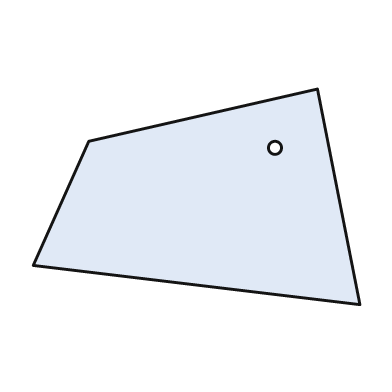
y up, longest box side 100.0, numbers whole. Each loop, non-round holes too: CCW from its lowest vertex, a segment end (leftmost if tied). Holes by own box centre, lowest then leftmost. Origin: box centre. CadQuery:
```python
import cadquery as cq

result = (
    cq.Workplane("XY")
    .moveTo(50.0, -33.0)
    .lineTo(37.0, 33.0)
    .lineTo(-33.0, 17.0)
    .lineTo(-50.0, -21.0)
    .close()
    .moveTo(24.0, 15.0)
    .circle(2.0)
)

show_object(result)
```